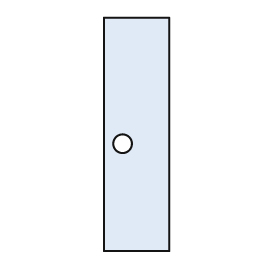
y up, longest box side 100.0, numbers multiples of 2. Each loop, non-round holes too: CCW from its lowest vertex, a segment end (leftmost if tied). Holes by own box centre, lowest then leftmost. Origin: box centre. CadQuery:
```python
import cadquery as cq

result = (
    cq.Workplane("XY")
    .moveTo(-14.0, -50.0)
    .lineTo(14.0, -50.0)
    .lineTo(14.0, 50.0)
    .lineTo(-14.0, 50.0)
    .close()
    .moveTo(-6.0, -4.0)
    .circle(4.0)
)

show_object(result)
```